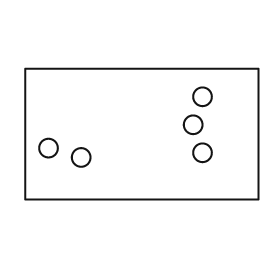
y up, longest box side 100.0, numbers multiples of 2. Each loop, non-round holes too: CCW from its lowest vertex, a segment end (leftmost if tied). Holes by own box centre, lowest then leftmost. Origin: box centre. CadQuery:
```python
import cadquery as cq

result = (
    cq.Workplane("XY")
    .moveTo(-50.0, -28.0)
    .lineTo(50.0, -28.0)
    .lineTo(50.0, 28.0)
    .lineTo(-50.0, 28.0)
    .close()
    .moveTo(-26.0, -10.0)
    .circle(4.0)
    .moveTo(26.0, -8.0)
    .circle(4.0)
    .moveTo(-40.0, -6.0)
    .circle(4.0)
    .moveTo(22.0, 4.0)
    .circle(4.0)
    .moveTo(26.0, 16.0)
    .circle(4.0)
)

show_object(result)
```